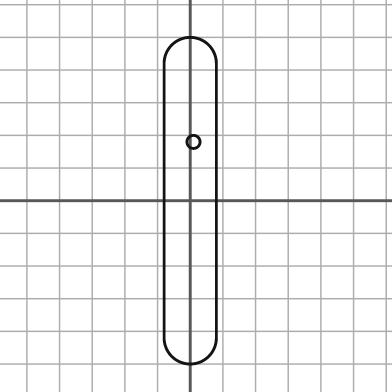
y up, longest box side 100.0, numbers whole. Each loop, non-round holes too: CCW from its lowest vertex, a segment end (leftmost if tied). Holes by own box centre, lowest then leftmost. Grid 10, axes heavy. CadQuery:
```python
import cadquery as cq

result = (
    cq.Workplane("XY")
    .moveTo(-8.0, -42.0)
    .threePointArc((0.0, -50.0), (8.0, -42.0))
    .lineTo(8.0, 42.0)
    .threePointArc((0.0, 50.0), (-8.0, 42.0))
    .close()
    .moveTo(1.0, 18.0)
    .circle(2.0)
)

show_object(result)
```